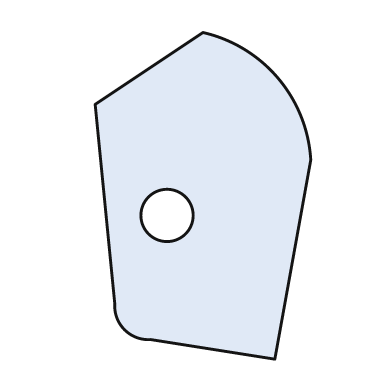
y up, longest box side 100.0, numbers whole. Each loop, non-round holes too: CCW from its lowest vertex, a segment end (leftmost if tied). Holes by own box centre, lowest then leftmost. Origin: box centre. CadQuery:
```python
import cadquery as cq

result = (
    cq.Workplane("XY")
    .moveTo(22.0, -50.0)
    .lineTo(33.0, 11.0)
    .threePointArc((23.0, 36.0), (0.0, 50.0))
    .lineTo(-33.0, 28.0)
    .lineTo(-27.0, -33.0)
    .threePointArc((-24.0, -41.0), (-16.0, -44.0))
    .close()
    .moveTo(-11.0, -6.0)
    .circle(8.0)
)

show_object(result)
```